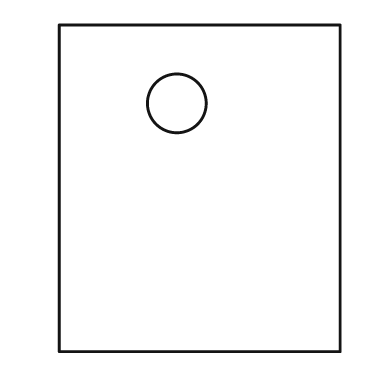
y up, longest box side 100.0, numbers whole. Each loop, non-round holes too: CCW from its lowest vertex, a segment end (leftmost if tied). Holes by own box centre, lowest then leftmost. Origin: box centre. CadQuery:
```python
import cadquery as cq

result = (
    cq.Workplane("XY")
    .moveTo(-43.0, -50.0)
    .lineTo(43.0, -50.0)
    .lineTo(43.0, 50.0)
    .lineTo(-43.0, 50.0)
    .close()
    .moveTo(-7.0, 26.0)
    .circle(9.0)
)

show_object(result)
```